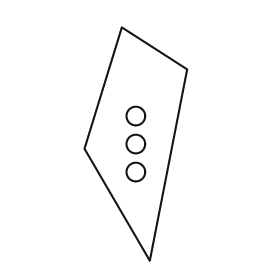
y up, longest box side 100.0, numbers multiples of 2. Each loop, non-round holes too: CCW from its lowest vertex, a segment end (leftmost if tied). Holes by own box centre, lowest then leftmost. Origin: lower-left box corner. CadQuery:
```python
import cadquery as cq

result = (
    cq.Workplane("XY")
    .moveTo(28.0, 0.0)
    .lineTo(44.0, 82.0)
    .lineTo(16.0, 100.0)
    .lineTo(0.0, 48.0)
    .close()
    .moveTo(22.0, 38.0)
    .circle(4.0)
    .moveTo(22.0, 50.0)
    .circle(4.0)
    .moveTo(22.0, 62.0)
    .circle(4.0)
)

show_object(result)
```